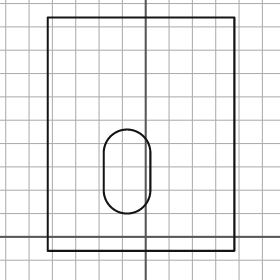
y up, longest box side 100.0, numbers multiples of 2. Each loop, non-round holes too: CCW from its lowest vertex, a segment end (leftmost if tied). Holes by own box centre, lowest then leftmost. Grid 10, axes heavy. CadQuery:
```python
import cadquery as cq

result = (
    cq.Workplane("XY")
    .moveTo(-42.0, -6.0)
    .lineTo(38.0, -6.0)
    .lineTo(38.0, 94.0)
    .lineTo(-42.0, 94.0)
    .close()
    .moveTo(-18.0, 20.0)
    .threePointArc((-8.0, 10.0), (2.0, 20.0))
    .lineTo(2.0, 36.0)
    .threePointArc((-8.0, 46.0), (-18.0, 36.0))
    .close()
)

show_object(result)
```